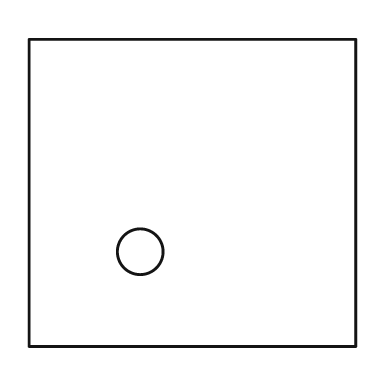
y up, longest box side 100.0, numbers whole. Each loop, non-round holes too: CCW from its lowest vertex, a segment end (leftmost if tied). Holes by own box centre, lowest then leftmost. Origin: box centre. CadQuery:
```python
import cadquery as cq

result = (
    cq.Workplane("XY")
    .moveTo(-50.0, -47.0)
    .lineTo(50.0, -47.0)
    .lineTo(50.0, 47.0)
    .lineTo(-50.0, 47.0)
    .close()
    .moveTo(-16.0, -18.0)
    .circle(7.0)
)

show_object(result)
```